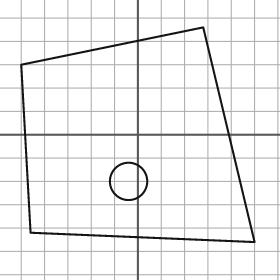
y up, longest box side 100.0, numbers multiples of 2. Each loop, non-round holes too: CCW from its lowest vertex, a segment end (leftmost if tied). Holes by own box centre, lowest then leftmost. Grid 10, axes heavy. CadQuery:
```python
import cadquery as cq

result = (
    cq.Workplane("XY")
    .moveTo(50.0, -46.0)
    .lineTo(28.0, 46.0)
    .lineTo(-50.0, 30.0)
    .lineTo(-46.0, -42.0)
    .close()
    .moveTo(-4.0, -20.0)
    .circle(8.0)
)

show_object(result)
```